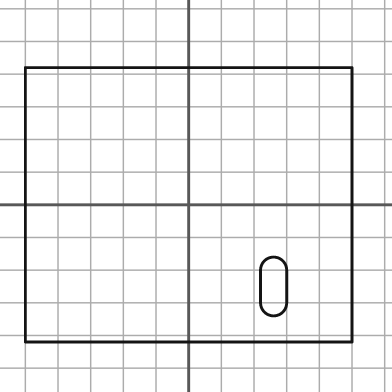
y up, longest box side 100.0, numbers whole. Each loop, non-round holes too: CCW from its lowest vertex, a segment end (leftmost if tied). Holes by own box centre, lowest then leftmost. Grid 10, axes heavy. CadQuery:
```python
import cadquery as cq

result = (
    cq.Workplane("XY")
    .moveTo(-50.0, -42.0)
    .lineTo(50.0, -42.0)
    .lineTo(50.0, 42.0)
    .lineTo(-50.0, 42.0)
    .close()
    .moveTo(22.0, -30.0)
    .threePointArc((26.0, -34.0), (30.0, -30.0))
    .lineTo(30.0, -20.0)
    .threePointArc((26.0, -16.0), (22.0, -20.0))
    .close()
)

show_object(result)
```